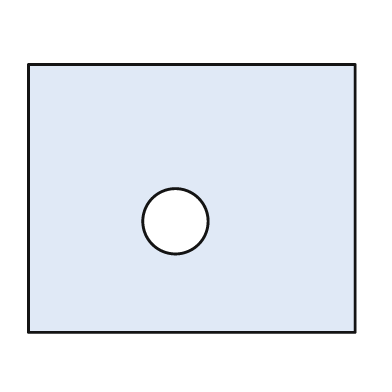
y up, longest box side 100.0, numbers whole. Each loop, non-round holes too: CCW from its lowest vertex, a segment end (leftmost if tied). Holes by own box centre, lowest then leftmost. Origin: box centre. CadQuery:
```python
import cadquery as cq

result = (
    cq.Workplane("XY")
    .moveTo(-50.0, -41.0)
    .lineTo(50.0, -41.0)
    .lineTo(50.0, 41.0)
    .lineTo(-50.0, 41.0)
    .close()
    .moveTo(-5.0, -7.0)
    .circle(10.0)
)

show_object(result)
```